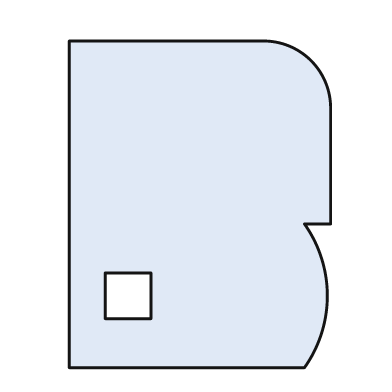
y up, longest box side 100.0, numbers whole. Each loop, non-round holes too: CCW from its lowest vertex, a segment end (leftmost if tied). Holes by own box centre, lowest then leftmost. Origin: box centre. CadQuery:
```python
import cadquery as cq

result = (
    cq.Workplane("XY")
    .moveTo(-40.0, -50.0)
    .lineTo(32.0, -50.0)
    .threePointArc((39.0, -28.0), (32.0, -6.0))
    .lineTo(40.0, -6.0)
    .lineTo(40.0, 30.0)
    .threePointArc((34.0, 44.0), (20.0, 50.0))
    .lineTo(-40.0, 50.0)
    .close()
    .moveTo(-29.0, -35.0)
    .lineTo(-15.0, -35.0)
    .lineTo(-15.0, -21.0)
    .lineTo(-29.0, -21.0)
    .close()
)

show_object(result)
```